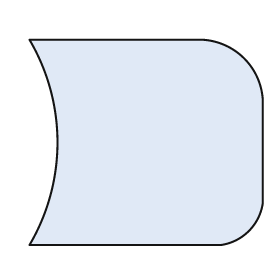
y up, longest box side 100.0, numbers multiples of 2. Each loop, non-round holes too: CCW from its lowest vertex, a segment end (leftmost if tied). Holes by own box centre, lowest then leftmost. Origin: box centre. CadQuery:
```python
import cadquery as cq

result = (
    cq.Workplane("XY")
    .moveTo(-50.0, -44.0)
    .lineTo(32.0, -44.0)
    .threePointArc((44.0, -38.0), (50.0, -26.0))
    .lineTo(50.0, 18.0)
    .threePointArc((42.0, 36.0), (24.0, 44.0))
    .lineTo(-50.0, 44.0)
    .threePointArc((-38.0, 0.0), (-50.0, -44.0))
    .close()
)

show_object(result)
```